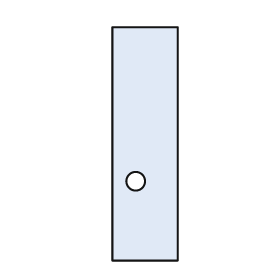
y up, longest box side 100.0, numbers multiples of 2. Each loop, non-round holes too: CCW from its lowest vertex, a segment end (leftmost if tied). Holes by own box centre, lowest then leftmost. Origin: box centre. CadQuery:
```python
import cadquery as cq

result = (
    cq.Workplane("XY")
    .moveTo(-14.0, -50.0)
    .lineTo(14.0, -50.0)
    .lineTo(14.0, 50.0)
    .lineTo(-14.0, 50.0)
    .close()
    .moveTo(-4.0, -16.0)
    .circle(4.0)
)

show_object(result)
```